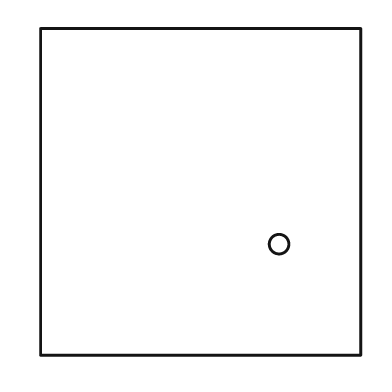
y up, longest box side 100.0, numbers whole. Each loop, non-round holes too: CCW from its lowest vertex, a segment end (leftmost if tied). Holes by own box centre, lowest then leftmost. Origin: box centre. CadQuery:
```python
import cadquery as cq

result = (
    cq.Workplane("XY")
    .moveTo(-49.0, -50.0)
    .lineTo(49.0, -50.0)
    .lineTo(49.0, 50.0)
    .lineTo(-49.0, 50.0)
    .close()
    .moveTo(24.0, -16.0)
    .circle(3.0)
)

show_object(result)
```